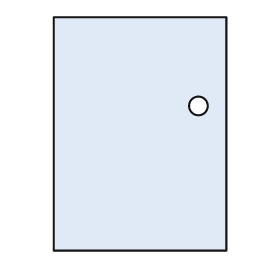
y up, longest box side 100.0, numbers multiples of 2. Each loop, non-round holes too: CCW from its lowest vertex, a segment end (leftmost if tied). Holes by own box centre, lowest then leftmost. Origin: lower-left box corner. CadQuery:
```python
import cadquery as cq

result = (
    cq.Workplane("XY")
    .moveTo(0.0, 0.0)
    .lineTo(74.0, 0.0)
    .lineTo(74.0, 100.0)
    .lineTo(0.0, 100.0)
    .close()
    .moveTo(62.0, 62.0)
    .circle(4.0)
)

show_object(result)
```